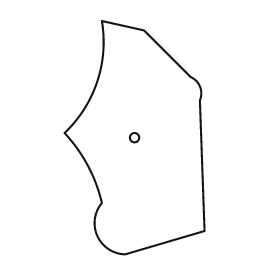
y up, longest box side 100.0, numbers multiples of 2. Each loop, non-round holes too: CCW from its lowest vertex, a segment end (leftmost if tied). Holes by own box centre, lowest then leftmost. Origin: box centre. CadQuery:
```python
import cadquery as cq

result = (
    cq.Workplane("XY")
    .moveTo(-4.0, -50.0)
    .lineTo(30.0, -40.0)
    .lineTo(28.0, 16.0)
    .threePointArc((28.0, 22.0), (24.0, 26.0))
    .lineTo(4.0, 46.0)
    .lineTo(-14.0, 50.0)
    .threePointArc((-16.0, 24.0), (-30.0, 2.0))
    .threePointArc((-20.0, -12.0), (-14.0, -28.0))
    .threePointArc((-16.0, -42.0), (-4.0, -50.0))
    .close()
    .moveTo(0.0, 0.0)
    .circle(2.0)
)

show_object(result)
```